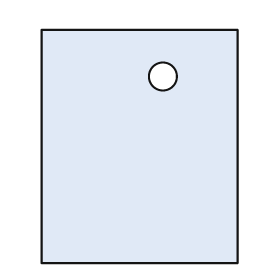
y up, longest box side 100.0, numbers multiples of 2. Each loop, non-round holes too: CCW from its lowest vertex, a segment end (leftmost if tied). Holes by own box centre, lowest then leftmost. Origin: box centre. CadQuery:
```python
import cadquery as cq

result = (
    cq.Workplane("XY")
    .moveTo(-42.0, -50.0)
    .lineTo(42.0, -50.0)
    .lineTo(42.0, 50.0)
    .lineTo(-42.0, 50.0)
    .close()
    .moveTo(10.0, 30.0)
    .circle(6.0)
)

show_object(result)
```